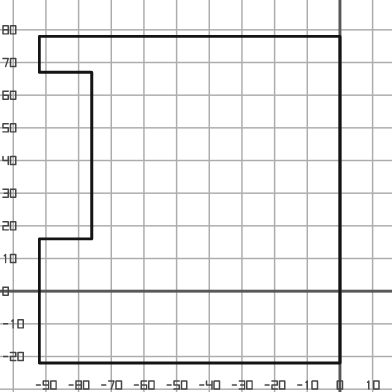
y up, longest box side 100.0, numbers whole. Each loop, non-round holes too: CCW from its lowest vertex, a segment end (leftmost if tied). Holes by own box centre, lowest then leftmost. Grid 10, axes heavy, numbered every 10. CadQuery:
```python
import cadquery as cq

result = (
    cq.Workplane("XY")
    .moveTo(-92.0, -22.0)
    .lineTo(0.0, -22.0)
    .lineTo(0.0, 78.0)
    .lineTo(-92.0, 78.0)
    .lineTo(-92.0, 67.0)
    .lineTo(-76.0, 67.0)
    .lineTo(-76.0, 16.0)
    .lineTo(-92.0, 16.0)
    .close()
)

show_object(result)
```